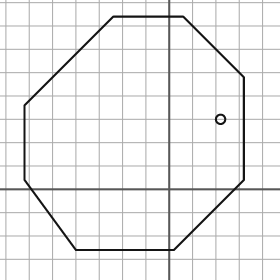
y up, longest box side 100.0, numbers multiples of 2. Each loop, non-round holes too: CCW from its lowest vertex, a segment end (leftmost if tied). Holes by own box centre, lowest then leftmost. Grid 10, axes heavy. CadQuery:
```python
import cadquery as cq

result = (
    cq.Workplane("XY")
    .moveTo(-40.0, -26.0)
    .lineTo(2.0, -26.0)
    .lineTo(32.0, 4.0)
    .lineTo(32.0, 48.0)
    .lineTo(6.0, 74.0)
    .lineTo(-24.0, 74.0)
    .lineTo(-62.0, 36.0)
    .lineTo(-62.0, 4.0)
    .close()
    .moveTo(22.0, 30.0)
    .circle(2.0)
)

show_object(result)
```